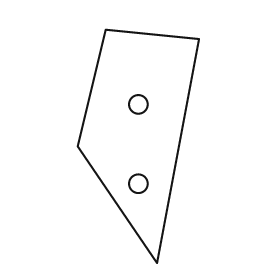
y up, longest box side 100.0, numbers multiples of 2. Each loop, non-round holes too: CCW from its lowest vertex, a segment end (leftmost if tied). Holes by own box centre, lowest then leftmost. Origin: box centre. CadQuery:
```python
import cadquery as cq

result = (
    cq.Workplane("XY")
    .moveTo(8.0, -50.0)
    .lineTo(26.0, 46.0)
    .lineTo(-14.0, 50.0)
    .lineTo(-26.0, 0.0)
    .close()
    .moveTo(0.0, -16.0)
    .circle(4.0)
    .moveTo(0.0, 18.0)
    .circle(4.0)
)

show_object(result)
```